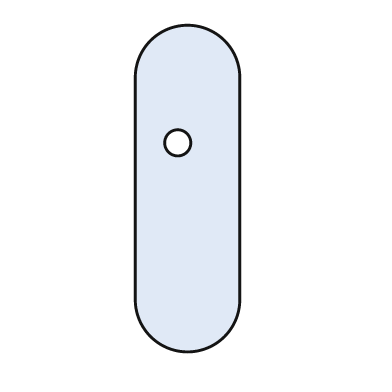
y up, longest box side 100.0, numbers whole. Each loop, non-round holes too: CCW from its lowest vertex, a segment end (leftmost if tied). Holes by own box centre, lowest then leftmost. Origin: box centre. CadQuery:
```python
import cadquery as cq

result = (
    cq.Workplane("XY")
    .moveTo(-16.0, -34.0)
    .threePointArc((0.0, -50.0), (16.0, -34.0))
    .lineTo(16.0, 34.0)
    .threePointArc((0.0, 50.0), (-16.0, 34.0))
    .close()
    .moveTo(-3.0, 14.0)
    .circle(4.0)
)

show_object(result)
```